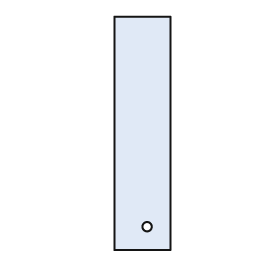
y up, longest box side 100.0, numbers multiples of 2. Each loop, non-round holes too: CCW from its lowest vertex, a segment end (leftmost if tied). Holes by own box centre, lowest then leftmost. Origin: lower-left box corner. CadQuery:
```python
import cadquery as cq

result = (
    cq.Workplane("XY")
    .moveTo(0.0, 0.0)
    .lineTo(24.0, 0.0)
    .lineTo(24.0, 100.0)
    .lineTo(0.0, 100.0)
    .close()
    .moveTo(14.0, 10.0)
    .circle(2.0)
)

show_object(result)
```